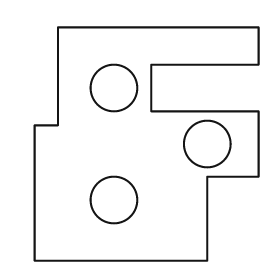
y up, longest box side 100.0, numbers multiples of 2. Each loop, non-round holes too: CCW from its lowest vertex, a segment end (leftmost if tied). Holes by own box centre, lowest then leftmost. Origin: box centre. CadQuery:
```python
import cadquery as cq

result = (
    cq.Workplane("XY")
    .moveTo(-48.0, -50.0)
    .lineTo(26.0, -50.0)
    .lineTo(26.0, -14.0)
    .lineTo(48.0, -14.0)
    .lineTo(48.0, 14.0)
    .lineTo(2.0, 14.0)
    .lineTo(2.0, 34.0)
    .lineTo(48.0, 34.0)
    .lineTo(48.0, 50.0)
    .lineTo(-38.0, 50.0)
    .lineTo(-38.0, 8.0)
    .lineTo(-48.0, 8.0)
    .close()
    .moveTo(-14.0, -24.0)
    .circle(10.0)
    .moveTo(26.0, 0.0)
    .circle(10.0)
    .moveTo(-14.0, 24.0)
    .circle(10.0)
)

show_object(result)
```